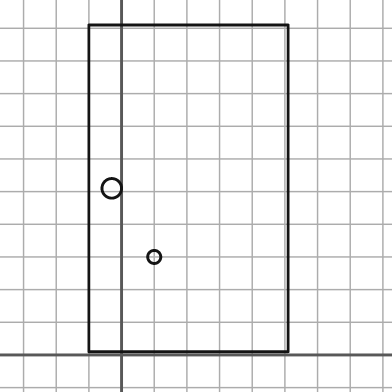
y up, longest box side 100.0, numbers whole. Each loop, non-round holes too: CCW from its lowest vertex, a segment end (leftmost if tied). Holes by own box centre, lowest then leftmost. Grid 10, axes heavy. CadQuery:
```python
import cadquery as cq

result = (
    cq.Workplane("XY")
    .moveTo(-10.0, 1.0)
    .lineTo(51.0, 1.0)
    .lineTo(51.0, 101.0)
    .lineTo(-10.0, 101.0)
    .close()
    .moveTo(10.0, 30.0)
    .circle(2.0)
    .moveTo(-3.0, 51.0)
    .circle(3.0)
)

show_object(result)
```